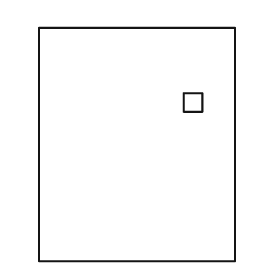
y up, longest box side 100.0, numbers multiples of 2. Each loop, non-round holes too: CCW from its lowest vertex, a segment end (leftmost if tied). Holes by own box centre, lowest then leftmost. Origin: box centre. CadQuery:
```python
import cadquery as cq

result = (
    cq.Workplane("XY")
    .moveTo(-42.0, -50.0)
    .lineTo(42.0, -50.0)
    .lineTo(42.0, 50.0)
    .lineTo(-42.0, 50.0)
    .close()
    .moveTo(20.0, 14.0)
    .lineTo(28.0, 14.0)
    .lineTo(28.0, 22.0)
    .lineTo(20.0, 22.0)
    .close()
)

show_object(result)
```